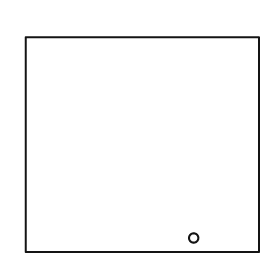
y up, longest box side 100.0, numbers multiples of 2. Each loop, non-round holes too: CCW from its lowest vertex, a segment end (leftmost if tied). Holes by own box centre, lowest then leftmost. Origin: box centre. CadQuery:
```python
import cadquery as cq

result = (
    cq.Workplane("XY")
    .moveTo(-50.0, -46.0)
    .lineTo(50.0, -46.0)
    .lineTo(50.0, 46.0)
    .lineTo(-50.0, 46.0)
    .close()
    .moveTo(22.0, -40.0)
    .circle(2.0)
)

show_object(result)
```